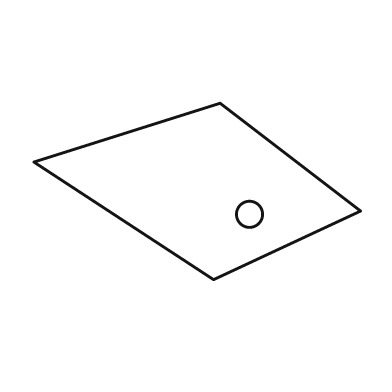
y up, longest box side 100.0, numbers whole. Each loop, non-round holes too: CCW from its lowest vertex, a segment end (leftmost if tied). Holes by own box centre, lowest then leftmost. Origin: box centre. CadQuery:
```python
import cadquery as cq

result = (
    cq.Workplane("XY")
    .moveTo(5.0, -27.0)
    .lineTo(50.0, -6.0)
    .lineTo(7.0, 27.0)
    .lineTo(-50.0, 9.0)
    .close()
    .moveTo(16.0, -7.0)
    .circle(4.0)
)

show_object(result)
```